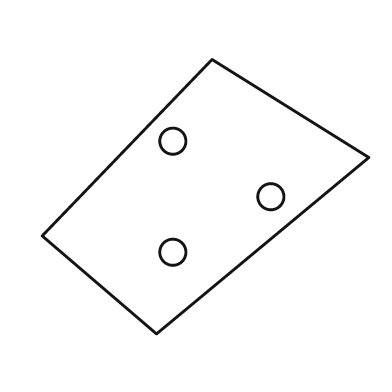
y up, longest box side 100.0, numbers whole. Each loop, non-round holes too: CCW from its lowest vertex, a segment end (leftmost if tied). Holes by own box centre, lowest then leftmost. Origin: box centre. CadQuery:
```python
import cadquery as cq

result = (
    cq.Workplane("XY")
    .moveTo(-15.0, -42.0)
    .lineTo(50.0, 12.0)
    .lineTo(2.0, 42.0)
    .lineTo(-50.0, -12.0)
    .close()
    .moveTo(-10.0, -17.0)
    .circle(4.0)
    .moveTo(20.0, 0.0)
    .circle(4.0)
    .moveTo(-10.0, 17.0)
    .circle(4.0)
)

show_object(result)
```